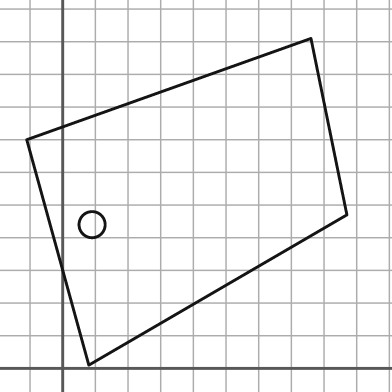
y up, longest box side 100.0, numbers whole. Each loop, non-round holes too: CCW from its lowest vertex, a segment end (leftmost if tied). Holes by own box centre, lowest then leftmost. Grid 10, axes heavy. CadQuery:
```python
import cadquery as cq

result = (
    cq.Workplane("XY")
    .moveTo(8.0, 1.0)
    .lineTo(87.0, 47.0)
    .lineTo(76.0, 101.0)
    .lineTo(-11.0, 70.0)
    .close()
    .moveTo(9.0, 44.0)
    .circle(4.0)
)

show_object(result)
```